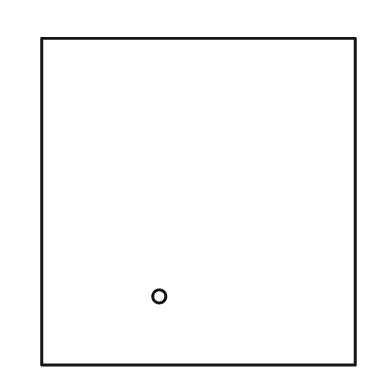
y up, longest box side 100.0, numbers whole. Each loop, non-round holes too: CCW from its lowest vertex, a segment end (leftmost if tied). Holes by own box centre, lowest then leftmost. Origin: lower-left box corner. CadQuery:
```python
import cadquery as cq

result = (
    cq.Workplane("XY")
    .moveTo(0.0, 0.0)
    .lineTo(96.0, 0.0)
    .lineTo(96.0, 100.0)
    .lineTo(0.0, 100.0)
    .close()
    .moveTo(36.0, 21.0)
    .circle(2.0)
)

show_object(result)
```